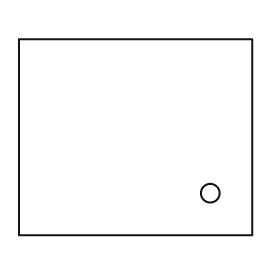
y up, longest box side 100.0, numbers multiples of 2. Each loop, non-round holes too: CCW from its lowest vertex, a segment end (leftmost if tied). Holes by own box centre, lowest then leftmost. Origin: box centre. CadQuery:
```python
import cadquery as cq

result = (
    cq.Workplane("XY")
    .moveTo(-50.0, -42.0)
    .lineTo(50.0, -42.0)
    .lineTo(50.0, 42.0)
    .lineTo(-50.0, 42.0)
    .close()
    .moveTo(32.0, -24.0)
    .circle(4.0)
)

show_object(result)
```